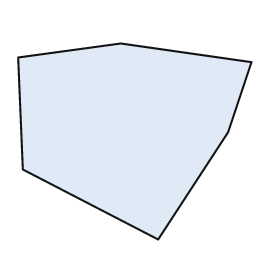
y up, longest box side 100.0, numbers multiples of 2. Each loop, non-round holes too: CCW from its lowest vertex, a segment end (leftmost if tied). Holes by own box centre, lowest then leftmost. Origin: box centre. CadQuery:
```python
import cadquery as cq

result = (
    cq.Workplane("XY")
    .moveTo(10.0, -42.0)
    .lineTo(40.0, 4.0)
    .lineTo(50.0, 34.0)
    .lineTo(-6.0, 42.0)
    .lineTo(-50.0, 36.0)
    .lineTo(-48.0, -12.0)
    .close()
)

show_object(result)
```